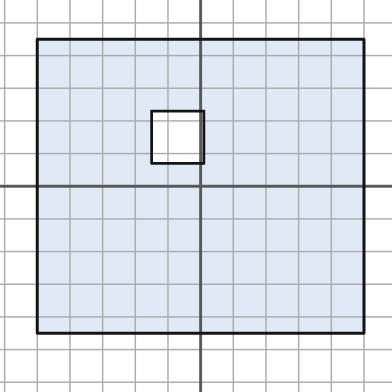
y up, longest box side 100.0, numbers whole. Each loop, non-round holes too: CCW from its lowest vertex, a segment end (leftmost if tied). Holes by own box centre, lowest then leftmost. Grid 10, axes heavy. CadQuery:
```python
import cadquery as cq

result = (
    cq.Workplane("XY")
    .moveTo(-50.0, -45.0)
    .lineTo(50.0, -45.0)
    .lineTo(50.0, 45.0)
    .lineTo(-50.0, 45.0)
    .close()
    .moveTo(-15.0, 7.0)
    .lineTo(1.0, 7.0)
    .lineTo(1.0, 23.0)
    .lineTo(-15.0, 23.0)
    .close()
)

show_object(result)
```